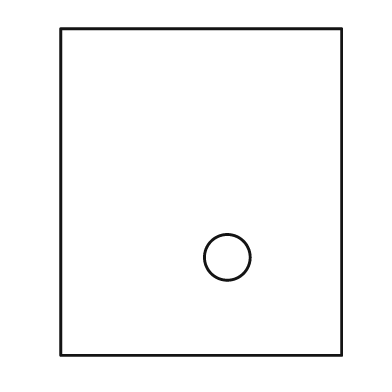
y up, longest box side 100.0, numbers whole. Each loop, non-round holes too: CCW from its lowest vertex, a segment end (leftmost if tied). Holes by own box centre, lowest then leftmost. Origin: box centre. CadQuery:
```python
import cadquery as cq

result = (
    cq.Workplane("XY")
    .moveTo(-43.0, -50.0)
    .lineTo(43.0, -50.0)
    .lineTo(43.0, 50.0)
    .lineTo(-43.0, 50.0)
    .close()
    .moveTo(8.0, -20.0)
    .circle(7.0)
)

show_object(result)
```